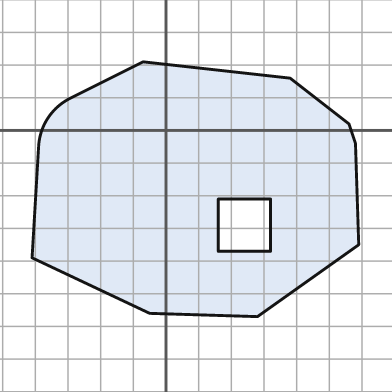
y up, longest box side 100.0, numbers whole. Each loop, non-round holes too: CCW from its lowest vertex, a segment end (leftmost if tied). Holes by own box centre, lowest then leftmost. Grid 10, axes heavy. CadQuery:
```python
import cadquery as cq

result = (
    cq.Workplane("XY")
    .moveTo(28.0, -57.0)
    .lineTo(59.0, -35.0)
    .lineTo(58.0, -4.0)
    .lineTo(56.0, 2.0)
    .lineTo(38.0, 16.0)
    .lineTo(-7.0, 21.0)
    .lineTo(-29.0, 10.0)
    .threePointArc((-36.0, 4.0), (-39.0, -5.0))
    .lineTo(-41.0, -39.0)
    .lineTo(-5.0, -56.0)
    .close()
    .moveTo(16.0, -37.0)
    .lineTo(32.0, -37.0)
    .lineTo(32.0, -21.0)
    .lineTo(16.0, -21.0)
    .close()
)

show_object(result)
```